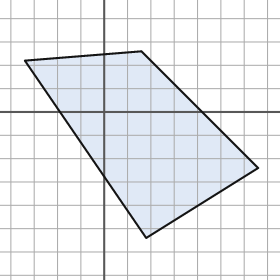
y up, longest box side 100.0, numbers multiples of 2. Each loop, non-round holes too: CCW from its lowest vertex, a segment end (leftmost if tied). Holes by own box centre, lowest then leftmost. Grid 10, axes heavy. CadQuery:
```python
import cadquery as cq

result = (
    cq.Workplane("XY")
    .moveTo(18.0, -54.0)
    .lineTo(66.0, -24.0)
    .lineTo(16.0, 26.0)
    .lineTo(-34.0, 22.0)
    .close()
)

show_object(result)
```